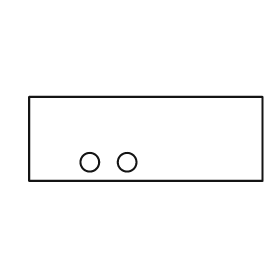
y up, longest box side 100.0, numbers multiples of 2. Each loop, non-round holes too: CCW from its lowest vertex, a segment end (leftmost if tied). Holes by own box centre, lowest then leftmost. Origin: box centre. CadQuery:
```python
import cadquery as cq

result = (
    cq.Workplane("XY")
    .moveTo(-50.0, -18.0)
    .lineTo(50.0, -18.0)
    .lineTo(50.0, 18.0)
    .lineTo(-50.0, 18.0)
    .close()
    .moveTo(-24.0, -10.0)
    .circle(4.0)
    .moveTo(-8.0, -10.0)
    .circle(4.0)
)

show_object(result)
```